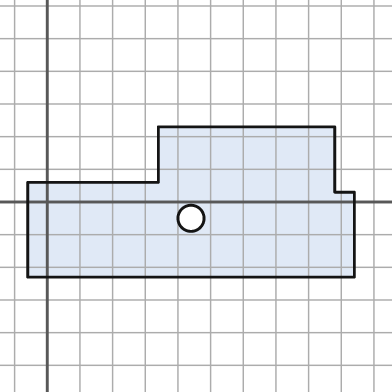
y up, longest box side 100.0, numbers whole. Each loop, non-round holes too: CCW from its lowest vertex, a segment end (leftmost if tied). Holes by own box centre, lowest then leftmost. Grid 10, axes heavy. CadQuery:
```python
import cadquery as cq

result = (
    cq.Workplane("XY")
    .moveTo(-6.0, -23.0)
    .lineTo(94.0, -23.0)
    .lineTo(94.0, 3.0)
    .lineTo(88.0, 3.0)
    .lineTo(88.0, 23.0)
    .lineTo(34.0, 23.0)
    .lineTo(34.0, 6.0)
    .lineTo(-6.0, 6.0)
    .close()
    .moveTo(44.0, -5.0)
    .circle(4.0)
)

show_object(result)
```